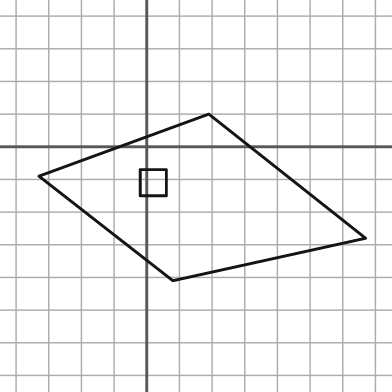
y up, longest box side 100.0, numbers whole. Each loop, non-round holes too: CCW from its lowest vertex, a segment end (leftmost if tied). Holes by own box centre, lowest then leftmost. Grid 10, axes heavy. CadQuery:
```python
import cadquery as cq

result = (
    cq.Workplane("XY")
    .moveTo(8.0, -41.0)
    .lineTo(67.0, -28.0)
    .lineTo(19.0, 10.0)
    .lineTo(-33.0, -9.0)
    .close()
    .moveTo(-2.0, -15.0)
    .lineTo(6.0, -15.0)
    .lineTo(6.0, -7.0)
    .lineTo(-2.0, -7.0)
    .close()
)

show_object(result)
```